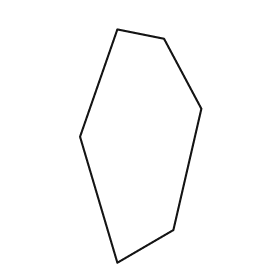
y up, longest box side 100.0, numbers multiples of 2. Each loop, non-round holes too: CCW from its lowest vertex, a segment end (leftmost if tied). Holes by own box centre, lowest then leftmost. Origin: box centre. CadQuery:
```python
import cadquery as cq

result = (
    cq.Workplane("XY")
    .moveTo(-10.0, -50.0)
    .lineTo(14.0, -36.0)
    .lineTo(26.0, 16.0)
    .lineTo(10.0, 46.0)
    .lineTo(-10.0, 50.0)
    .lineTo(-26.0, 4.0)
    .close()
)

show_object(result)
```